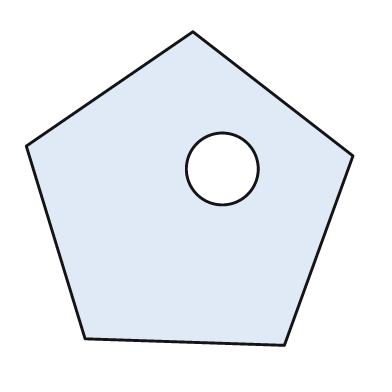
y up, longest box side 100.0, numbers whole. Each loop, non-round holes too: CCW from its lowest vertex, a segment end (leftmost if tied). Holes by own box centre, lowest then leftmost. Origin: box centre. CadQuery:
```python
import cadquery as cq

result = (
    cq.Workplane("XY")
    .moveTo(29.0, -48.0)
    .lineTo(50.0, 10.0)
    .lineTo(1.0, 48.0)
    .lineTo(-50.0, 13.0)
    .lineTo(-32.0, -46.0)
    .close()
    .moveTo(10.0, 6.0)
    .circle(11.0)
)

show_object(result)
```